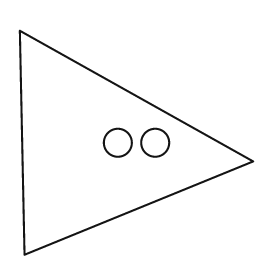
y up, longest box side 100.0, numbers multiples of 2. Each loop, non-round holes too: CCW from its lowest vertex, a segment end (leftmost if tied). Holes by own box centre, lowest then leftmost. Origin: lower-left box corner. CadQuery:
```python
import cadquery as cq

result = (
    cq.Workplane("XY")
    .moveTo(2.0, 0.0)
    .lineTo(100.0, 40.0)
    .lineTo(0.0, 96.0)
    .close()
    .moveTo(42.0, 48.0)
    .circle(6.0)
    .moveTo(58.0, 48.0)
    .circle(6.0)
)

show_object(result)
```